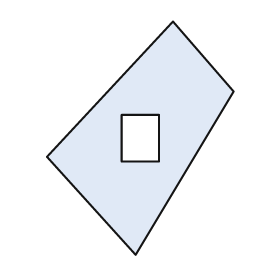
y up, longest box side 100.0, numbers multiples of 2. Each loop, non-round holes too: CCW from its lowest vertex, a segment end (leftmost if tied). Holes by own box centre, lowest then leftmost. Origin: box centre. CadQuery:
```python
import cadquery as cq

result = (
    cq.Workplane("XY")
    .moveTo(-2.0, -50.0)
    .lineTo(40.0, 20.0)
    .lineTo(14.0, 50.0)
    .lineTo(-40.0, -8.0)
    .close()
    .moveTo(-8.0, -10.0)
    .lineTo(8.0, -10.0)
    .lineTo(8.0, 10.0)
    .lineTo(-8.0, 10.0)
    .close()
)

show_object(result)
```